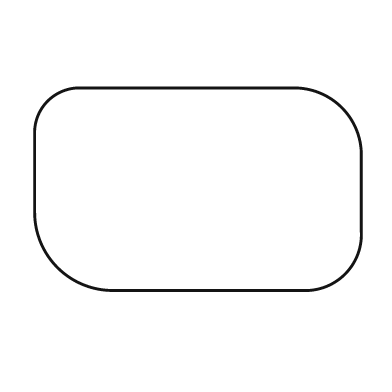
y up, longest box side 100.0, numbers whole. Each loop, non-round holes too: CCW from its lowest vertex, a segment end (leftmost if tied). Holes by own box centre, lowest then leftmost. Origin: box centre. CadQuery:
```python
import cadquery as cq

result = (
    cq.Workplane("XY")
    .moveTo(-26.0, -31.0)
    .lineTo(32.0, -31.0)
    .threePointArc((45.0, -26.0), (50.0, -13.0))
    .lineTo(50.0, 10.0)
    .threePointArc((44.0, 25.0), (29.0, 31.0))
    .lineTo(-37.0, 31.0)
    .threePointArc((-46.0, 27.0), (-50.0, 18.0))
    .lineTo(-50.0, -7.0)
    .threePointArc((-43.0, -24.0), (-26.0, -31.0))
    .close()
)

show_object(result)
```